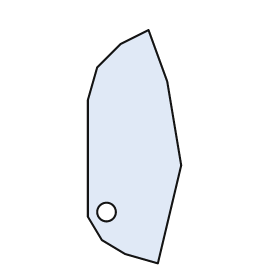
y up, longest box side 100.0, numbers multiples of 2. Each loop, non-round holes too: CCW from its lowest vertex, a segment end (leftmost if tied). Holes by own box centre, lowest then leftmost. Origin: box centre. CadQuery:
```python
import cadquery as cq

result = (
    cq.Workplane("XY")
    .moveTo(10.0, -50.0)
    .lineTo(20.0, -8.0)
    .lineTo(14.0, 28.0)
    .lineTo(6.0, 50.0)
    .lineTo(-6.0, 44.0)
    .lineTo(-16.0, 34.0)
    .lineTo(-20.0, 20.0)
    .lineTo(-20.0, -30.0)
    .lineTo(-14.0, -40.0)
    .lineTo(-4.0, -46.0)
    .close()
    .moveTo(-12.0, -28.0)
    .circle(4.0)
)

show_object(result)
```